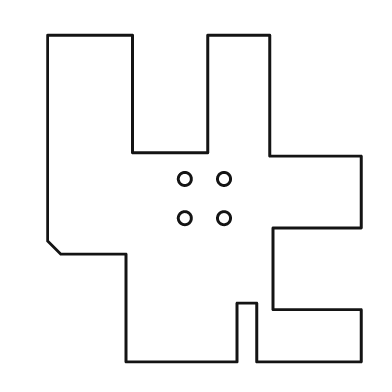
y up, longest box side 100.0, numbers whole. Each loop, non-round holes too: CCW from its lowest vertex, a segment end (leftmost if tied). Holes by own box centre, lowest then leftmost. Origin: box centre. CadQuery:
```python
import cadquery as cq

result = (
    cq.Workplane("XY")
    .moveTo(-24.0, -50.0)
    .lineTo(10.0, -50.0)
    .lineTo(10.0, -32.0)
    .lineTo(16.0, -32.0)
    .lineTo(16.0, -50.0)
    .lineTo(48.0, -50.0)
    .lineTo(48.0, -34.0)
    .lineTo(21.0, -34.0)
    .lineTo(21.0, -9.0)
    .lineTo(48.0, -9.0)
    .lineTo(48.0, 13.0)
    .lineTo(20.0, 13.0)
    .lineTo(20.0, 50.0)
    .lineTo(1.0, 50.0)
    .lineTo(1.0, 14.0)
    .lineTo(-22.0, 14.0)
    .lineTo(-22.0, 50.0)
    .lineTo(-48.0, 50.0)
    .lineTo(-48.0, -13.0)
    .lineTo(-44.0, -17.0)
    .lineTo(-24.0, -17.0)
    .close()
    .moveTo(-6.0, -6.0)
    .circle(2.0)
    .moveTo(6.0, -6.0)
    .circle(2.0)
    .moveTo(-6.0, 6.0)
    .circle(2.0)
    .moveTo(6.0, 6.0)
    .circle(2.0)
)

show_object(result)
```